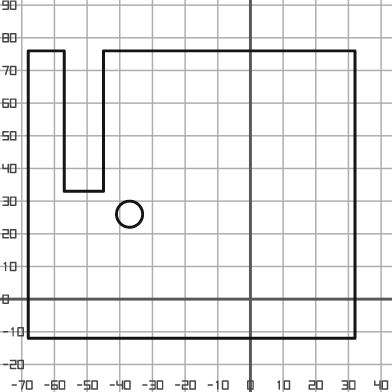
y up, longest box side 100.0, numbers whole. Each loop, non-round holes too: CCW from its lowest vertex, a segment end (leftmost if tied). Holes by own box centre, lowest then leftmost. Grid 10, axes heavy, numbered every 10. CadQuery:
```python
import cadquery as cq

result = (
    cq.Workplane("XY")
    .moveTo(-68.0, -12.0)
    .lineTo(32.0, -12.0)
    .lineTo(32.0, 76.0)
    .lineTo(-45.0, 76.0)
    .lineTo(-45.0, 33.0)
    .lineTo(-57.0, 33.0)
    .lineTo(-57.0, 76.0)
    .lineTo(-68.0, 76.0)
    .close()
    .moveTo(-37.0, 26.0)
    .circle(4.0)
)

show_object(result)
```